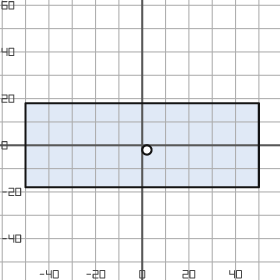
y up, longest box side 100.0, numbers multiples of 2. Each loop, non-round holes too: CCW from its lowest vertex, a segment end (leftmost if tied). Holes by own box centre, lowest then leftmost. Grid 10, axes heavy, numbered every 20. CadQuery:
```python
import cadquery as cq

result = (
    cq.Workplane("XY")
    .moveTo(-50.0, -18.0)
    .lineTo(50.0, -18.0)
    .lineTo(50.0, 18.0)
    .lineTo(-50.0, 18.0)
    .close()
    .moveTo(2.0, -2.0)
    .circle(2.0)
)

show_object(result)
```